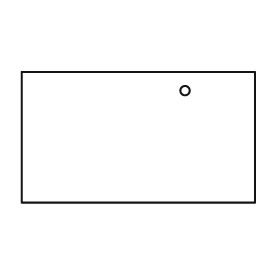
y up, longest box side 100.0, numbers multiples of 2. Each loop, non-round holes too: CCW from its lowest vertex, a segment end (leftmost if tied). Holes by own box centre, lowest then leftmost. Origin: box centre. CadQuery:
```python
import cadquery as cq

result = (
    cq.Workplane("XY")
    .moveTo(-50.0, -28.0)
    .lineTo(50.0, -28.0)
    .lineTo(50.0, 28.0)
    .lineTo(-50.0, 28.0)
    .close()
    .moveTo(20.0, 20.0)
    .circle(2.0)
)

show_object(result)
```